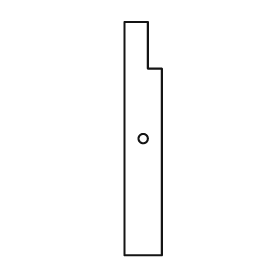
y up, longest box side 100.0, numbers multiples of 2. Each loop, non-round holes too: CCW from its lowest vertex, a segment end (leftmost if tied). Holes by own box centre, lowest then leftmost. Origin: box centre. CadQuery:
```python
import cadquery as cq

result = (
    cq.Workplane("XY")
    .moveTo(-8.0, -50.0)
    .lineTo(8.0, -50.0)
    .lineTo(8.0, 30.0)
    .lineTo(2.0, 30.0)
    .lineTo(2.0, 50.0)
    .lineTo(-8.0, 50.0)
    .close()
    .moveTo(0.0, 0.0)
    .circle(2.0)
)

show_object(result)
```